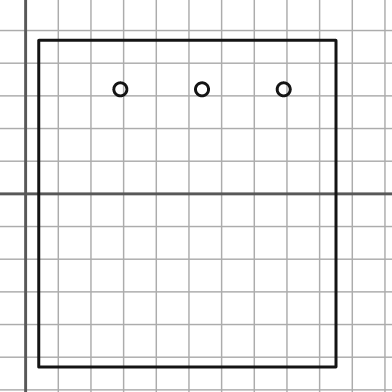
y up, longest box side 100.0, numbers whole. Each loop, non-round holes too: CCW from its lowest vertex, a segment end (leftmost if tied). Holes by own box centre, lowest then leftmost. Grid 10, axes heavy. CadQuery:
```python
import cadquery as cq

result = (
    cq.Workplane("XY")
    .moveTo(4.0, -53.0)
    .lineTo(95.0, -53.0)
    .lineTo(95.0, 47.0)
    .lineTo(4.0, 47.0)
    .close()
    .moveTo(29.0, 32.0)
    .circle(2.0)
    .moveTo(54.0, 32.0)
    .circle(2.0)
    .moveTo(79.0, 32.0)
    .circle(2.0)
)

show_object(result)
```